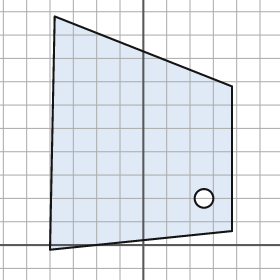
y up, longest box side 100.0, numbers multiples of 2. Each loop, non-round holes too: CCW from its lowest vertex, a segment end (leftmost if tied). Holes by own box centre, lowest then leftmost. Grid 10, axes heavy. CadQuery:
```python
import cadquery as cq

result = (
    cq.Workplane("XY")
    .moveTo(-40.0, -2.0)
    .lineTo(38.0, 6.0)
    .lineTo(38.0, 68.0)
    .lineTo(-38.0, 98.0)
    .close()
    .moveTo(26.0, 20.0)
    .circle(4.0)
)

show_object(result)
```